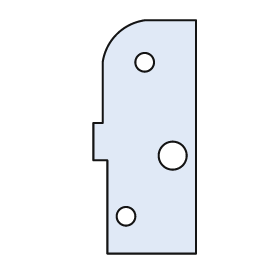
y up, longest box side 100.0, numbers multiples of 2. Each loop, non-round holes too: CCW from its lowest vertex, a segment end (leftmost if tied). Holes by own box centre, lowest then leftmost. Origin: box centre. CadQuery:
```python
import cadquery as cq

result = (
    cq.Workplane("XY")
    .moveTo(-16.0, -50.0)
    .lineTo(22.0, -50.0)
    .lineTo(22.0, 50.0)
    .lineTo(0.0, 50.0)
    .threePointArc((-12.0, 44.0), (-18.0, 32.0))
    .lineTo(-18.0, 6.0)
    .lineTo(-22.0, 6.0)
    .lineTo(-22.0, -10.0)
    .lineTo(-16.0, -10.0)
    .close()
    .moveTo(-8.0, -34.0)
    .circle(4.0)
    .moveTo(12.0, -8.0)
    .circle(6.0)
    .moveTo(0.0, 32.0)
    .circle(4.0)
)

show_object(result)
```